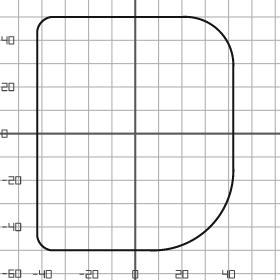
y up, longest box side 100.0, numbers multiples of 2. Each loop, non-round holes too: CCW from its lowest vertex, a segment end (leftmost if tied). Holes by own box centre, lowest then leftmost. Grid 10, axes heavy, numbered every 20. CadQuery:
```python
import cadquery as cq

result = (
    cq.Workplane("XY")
    .moveTo(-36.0, -50.0)
    .lineTo(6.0, -50.0)
    .threePointArc((32.0, -40.0), (42.0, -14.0))
    .lineTo(42.0, 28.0)
    .threePointArc((36.0, 44.0), (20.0, 50.0))
    .lineTo(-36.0, 50.0)
    .threePointArc((-40.0, 48.0), (-42.0, 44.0))
    .lineTo(-42.0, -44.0)
    .threePointArc((-40.0, -48.0), (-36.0, -50.0))
    .close()
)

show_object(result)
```